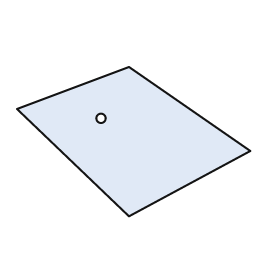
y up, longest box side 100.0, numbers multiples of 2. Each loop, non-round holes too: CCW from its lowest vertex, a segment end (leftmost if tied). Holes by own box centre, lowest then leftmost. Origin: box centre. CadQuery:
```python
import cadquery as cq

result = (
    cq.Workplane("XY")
    .moveTo(-2.0, -32.0)
    .lineTo(50.0, -4.0)
    .lineTo(-2.0, 32.0)
    .lineTo(-50.0, 14.0)
    .close()
    .moveTo(-14.0, 10.0)
    .circle(2.0)
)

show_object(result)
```